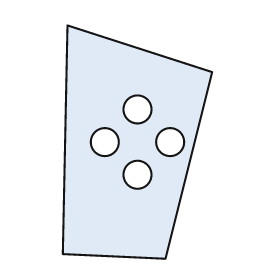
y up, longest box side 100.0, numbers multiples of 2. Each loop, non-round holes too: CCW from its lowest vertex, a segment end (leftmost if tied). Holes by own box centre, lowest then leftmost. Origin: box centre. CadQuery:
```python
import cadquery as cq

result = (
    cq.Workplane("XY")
    .moveTo(12.0, -50.0)
    .lineTo(32.0, 30.0)
    .lineTo(-30.0, 50.0)
    .lineTo(-32.0, -48.0)
    .close()
    .moveTo(0.0, -14.0)
    .circle(6.0)
    .moveTo(-14.0, 0.0)
    .circle(6.0)
    .moveTo(14.0, 0.0)
    .circle(6.0)
    .moveTo(0.0, 14.0)
    .circle(6.0)
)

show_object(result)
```